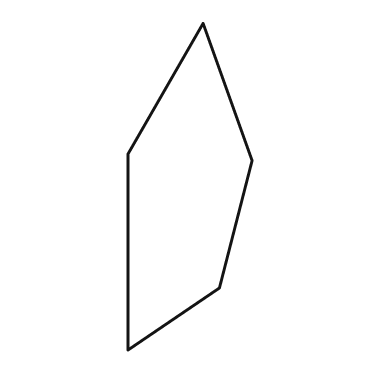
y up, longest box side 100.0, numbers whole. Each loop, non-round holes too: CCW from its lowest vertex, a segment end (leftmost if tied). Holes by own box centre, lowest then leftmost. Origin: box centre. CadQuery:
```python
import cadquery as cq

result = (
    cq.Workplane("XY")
    .moveTo(-19.0, -50.0)
    .lineTo(9.0, -31.0)
    .lineTo(19.0, 8.0)
    .lineTo(4.0, 50.0)
    .lineTo(-19.0, 10.0)
    .close()
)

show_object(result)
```